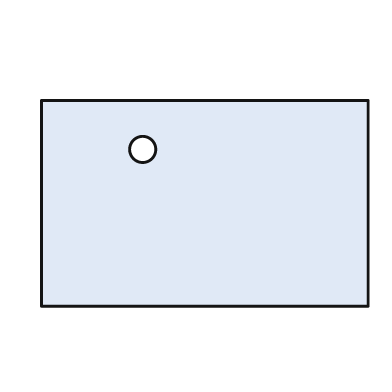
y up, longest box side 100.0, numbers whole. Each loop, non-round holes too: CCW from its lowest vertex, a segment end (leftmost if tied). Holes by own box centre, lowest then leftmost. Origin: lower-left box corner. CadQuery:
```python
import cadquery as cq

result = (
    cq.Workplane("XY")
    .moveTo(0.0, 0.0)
    .lineTo(100.0, 0.0)
    .lineTo(100.0, 63.0)
    .lineTo(0.0, 63.0)
    .close()
    .moveTo(31.0, 48.0)
    .circle(4.0)
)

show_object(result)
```